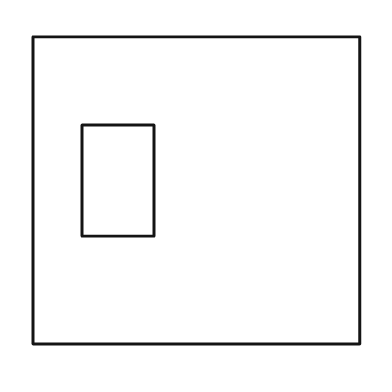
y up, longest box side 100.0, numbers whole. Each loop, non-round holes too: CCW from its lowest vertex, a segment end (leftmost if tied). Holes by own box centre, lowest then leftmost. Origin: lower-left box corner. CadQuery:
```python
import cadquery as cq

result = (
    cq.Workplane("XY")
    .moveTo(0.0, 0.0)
    .lineTo(100.0, 0.0)
    .lineTo(100.0, 94.0)
    .lineTo(0.0, 94.0)
    .close()
    .moveTo(15.0, 33.0)
    .lineTo(37.0, 33.0)
    .lineTo(37.0, 67.0)
    .lineTo(15.0, 67.0)
    .close()
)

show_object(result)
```